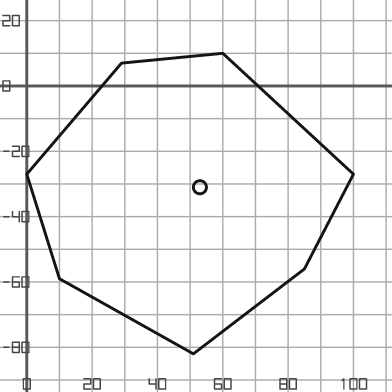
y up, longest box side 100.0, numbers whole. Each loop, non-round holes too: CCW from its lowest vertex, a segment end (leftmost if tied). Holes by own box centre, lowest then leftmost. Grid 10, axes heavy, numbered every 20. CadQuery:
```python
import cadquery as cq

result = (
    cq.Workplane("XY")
    .moveTo(51.0, -82.0)
    .lineTo(85.0, -56.0)
    .lineTo(100.0, -27.0)
    .lineTo(60.0, 10.0)
    .lineTo(29.0, 7.0)
    .lineTo(0.0, -27.0)
    .lineTo(10.0, -59.0)
    .close()
    .moveTo(53.0, -31.0)
    .circle(2.0)
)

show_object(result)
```